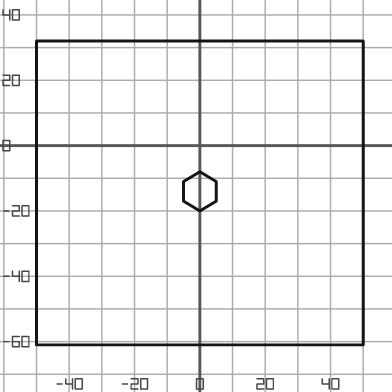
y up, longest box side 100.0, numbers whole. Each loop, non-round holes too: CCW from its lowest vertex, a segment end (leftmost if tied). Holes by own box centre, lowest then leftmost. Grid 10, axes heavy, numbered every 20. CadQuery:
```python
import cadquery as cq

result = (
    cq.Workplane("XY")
    .moveTo(-50.0, -61.0)
    .lineTo(50.0, -61.0)
    .lineTo(50.0, 32.0)
    .lineTo(-50.0, 32.0)
    .close()
    .moveTo(0.0, -20.0)
    .lineTo(5.0, -17.0)
    .lineTo(5.0, -11.0)
    .lineTo(0.0, -8.0)
    .lineTo(-5.0, -11.0)
    .lineTo(-5.0, -17.0)
    .close()
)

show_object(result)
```